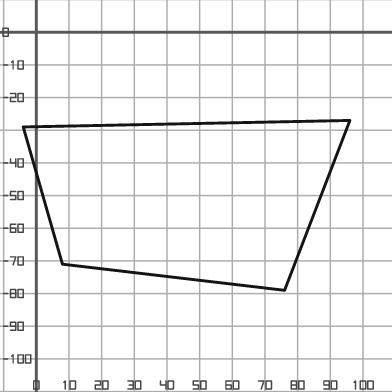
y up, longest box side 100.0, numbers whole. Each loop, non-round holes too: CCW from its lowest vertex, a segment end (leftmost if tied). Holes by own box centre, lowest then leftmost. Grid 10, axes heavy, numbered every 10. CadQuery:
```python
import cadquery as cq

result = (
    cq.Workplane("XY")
    .moveTo(76.0, -79.0)
    .lineTo(96.0, -27.0)
    .lineTo(-4.0, -29.0)
    .lineTo(8.0, -71.0)
    .close()
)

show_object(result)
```